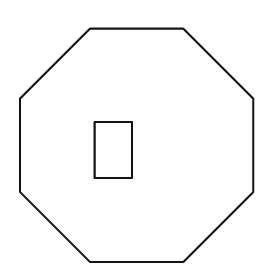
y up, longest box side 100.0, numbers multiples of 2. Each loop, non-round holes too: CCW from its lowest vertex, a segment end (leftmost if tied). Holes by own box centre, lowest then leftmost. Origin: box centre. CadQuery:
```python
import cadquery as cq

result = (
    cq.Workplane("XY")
    .moveTo(-20.0, -50.0)
    .lineTo(20.0, -50.0)
    .lineTo(50.0, -20.0)
    .lineTo(50.0, 20.0)
    .lineTo(20.0, 50.0)
    .lineTo(-20.0, 50.0)
    .lineTo(-50.0, 20.0)
    .lineTo(-50.0, -20.0)
    .close()
    .moveTo(-18.0, -14.0)
    .lineTo(-2.0, -14.0)
    .lineTo(-2.0, 10.0)
    .lineTo(-18.0, 10.0)
    .close()
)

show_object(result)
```